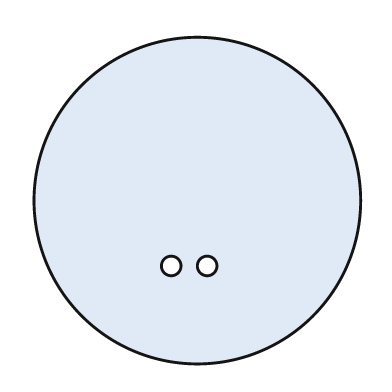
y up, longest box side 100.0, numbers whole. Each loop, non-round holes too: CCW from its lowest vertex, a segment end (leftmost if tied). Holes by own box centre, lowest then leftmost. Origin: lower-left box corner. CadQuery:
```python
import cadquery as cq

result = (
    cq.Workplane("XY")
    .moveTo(50.0, 50.0)
    .circle(50.0)
    .moveTo(42.0, 30.0)
    .circle(3.0)
    .moveTo(53.0, 30.0)
    .circle(3.0)
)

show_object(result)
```